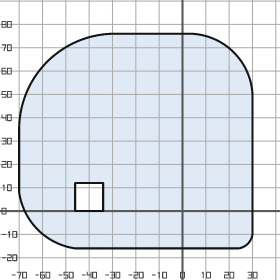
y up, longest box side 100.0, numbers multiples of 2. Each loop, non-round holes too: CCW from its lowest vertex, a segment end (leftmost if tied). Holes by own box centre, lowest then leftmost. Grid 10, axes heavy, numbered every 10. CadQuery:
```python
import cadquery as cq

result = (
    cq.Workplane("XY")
    .moveTo(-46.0, -16.0)
    .lineTo(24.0, -16.0)
    .threePointArc((28.0, -14.0), (30.0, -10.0))
    .lineTo(30.0, 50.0)
    .threePointArc((22.0, 68.0), (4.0, 76.0))
    .lineTo(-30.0, 76.0)
    .threePointArc((-58.0, 64.0), (-70.0, 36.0))
    .lineTo(-70.0, 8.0)
    .threePointArc((-62.0, -8.0), (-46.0, -16.0))
    .close()
    .moveTo(-46.0, 0.0)
    .lineTo(-34.0, 0.0)
    .lineTo(-34.0, 12.0)
    .lineTo(-46.0, 12.0)
    .close()
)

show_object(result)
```